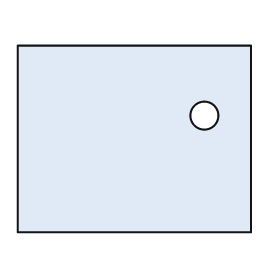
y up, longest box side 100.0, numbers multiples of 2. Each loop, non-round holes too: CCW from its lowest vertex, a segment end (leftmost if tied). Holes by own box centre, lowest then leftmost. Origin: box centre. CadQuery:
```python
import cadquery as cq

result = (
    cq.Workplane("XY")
    .moveTo(-50.0, -40.0)
    .lineTo(50.0, -40.0)
    .lineTo(50.0, 40.0)
    .lineTo(-50.0, 40.0)
    .close()
    .moveTo(30.0, 10.0)
    .circle(6.0)
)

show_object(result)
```